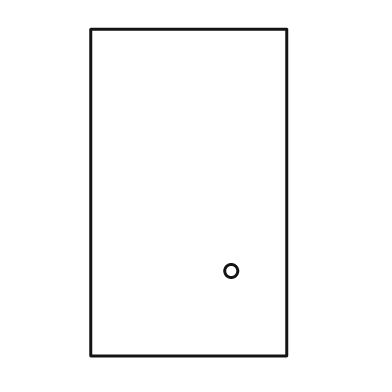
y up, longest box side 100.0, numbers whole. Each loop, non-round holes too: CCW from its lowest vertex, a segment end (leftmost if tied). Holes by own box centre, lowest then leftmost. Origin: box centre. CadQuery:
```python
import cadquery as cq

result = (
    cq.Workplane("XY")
    .moveTo(-30.0, -50.0)
    .lineTo(30.0, -50.0)
    .lineTo(30.0, 50.0)
    .lineTo(-30.0, 50.0)
    .close()
    .moveTo(13.0, -24.0)
    .circle(2.0)
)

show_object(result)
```